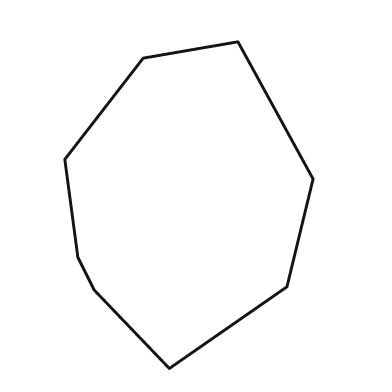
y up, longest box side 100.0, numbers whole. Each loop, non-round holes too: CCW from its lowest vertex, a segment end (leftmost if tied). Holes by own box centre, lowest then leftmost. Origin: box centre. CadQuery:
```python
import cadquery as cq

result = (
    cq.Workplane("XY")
    .moveTo(-6.0, -50.0)
    .lineTo(30.0, -25.0)
    .lineTo(38.0, 8.0)
    .lineTo(15.0, 50.0)
    .lineTo(-14.0, 45.0)
    .lineTo(-38.0, 14.0)
    .lineTo(-34.0, -16.0)
    .lineTo(-29.0, -26.0)
    .close()
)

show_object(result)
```